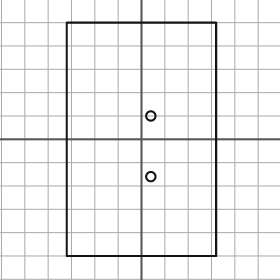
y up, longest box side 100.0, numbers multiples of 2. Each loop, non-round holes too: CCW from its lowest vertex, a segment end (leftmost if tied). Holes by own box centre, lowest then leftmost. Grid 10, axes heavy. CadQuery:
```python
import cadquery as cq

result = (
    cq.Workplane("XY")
    .moveTo(-32.0, -50.0)
    .lineTo(32.0, -50.0)
    .lineTo(32.0, 50.0)
    .lineTo(-32.0, 50.0)
    .close()
    .moveTo(4.0, -16.0)
    .circle(2.0)
    .moveTo(4.0, 10.0)
    .circle(2.0)
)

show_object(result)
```